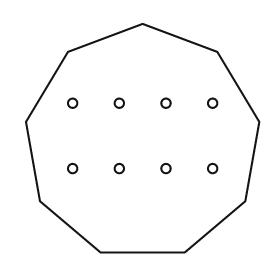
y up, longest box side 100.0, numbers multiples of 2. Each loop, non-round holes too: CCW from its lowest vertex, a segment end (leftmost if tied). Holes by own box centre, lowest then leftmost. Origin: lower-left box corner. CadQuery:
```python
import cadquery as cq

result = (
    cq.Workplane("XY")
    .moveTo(32.0, 0.0)
    .lineTo(68.0, 0.0)
    .lineTo(94.0, 22.0)
    .lineTo(100.0, 56.0)
    .lineTo(82.0, 86.0)
    .lineTo(50.0, 98.0)
    .lineTo(18.0, 86.0)
    .lineTo(0.0, 56.0)
    .lineTo(6.0, 22.0)
    .close()
    .moveTo(20.0, 36.0)
    .circle(2.0)
    .moveTo(40.0, 36.0)
    .circle(2.0)
    .moveTo(60.0, 36.0)
    .circle(2.0)
    .moveTo(80.0, 36.0)
    .circle(2.0)
    .moveTo(20.0, 64.0)
    .circle(2.0)
    .moveTo(40.0, 64.0)
    .circle(2.0)
    .moveTo(60.0, 64.0)
    .circle(2.0)
    .moveTo(80.0, 64.0)
    .circle(2.0)
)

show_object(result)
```